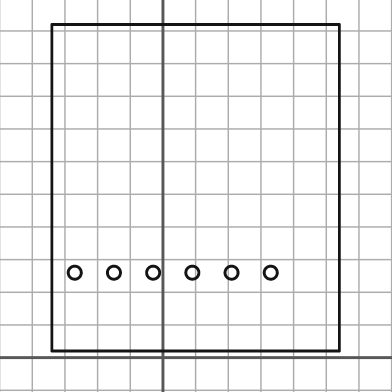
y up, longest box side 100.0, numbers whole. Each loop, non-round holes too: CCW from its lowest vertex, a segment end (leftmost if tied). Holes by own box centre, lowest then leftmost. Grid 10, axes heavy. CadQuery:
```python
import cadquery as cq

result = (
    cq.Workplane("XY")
    .moveTo(-34.0, 2.0)
    .lineTo(54.0, 2.0)
    .lineTo(54.0, 102.0)
    .lineTo(-34.0, 102.0)
    .close()
    .moveTo(-27.0, 26.0)
    .circle(2.0)
    .moveTo(-15.0, 26.0)
    .circle(2.0)
    .moveTo(-3.0, 26.0)
    .circle(2.0)
    .moveTo(9.0, 26.0)
    .circle(2.0)
    .moveTo(21.0, 26.0)
    .circle(2.0)
    .moveTo(33.0, 26.0)
    .circle(2.0)
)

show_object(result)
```